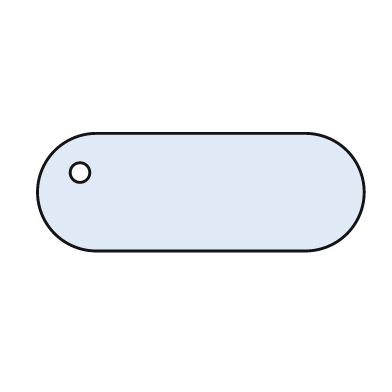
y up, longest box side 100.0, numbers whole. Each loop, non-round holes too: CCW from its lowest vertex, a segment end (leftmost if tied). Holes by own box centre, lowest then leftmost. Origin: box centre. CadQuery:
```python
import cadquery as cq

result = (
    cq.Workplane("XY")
    .moveTo(-32.0, -18.0)
    .lineTo(32.0, -18.0)
    .threePointArc((50.0, 0.0), (32.0, 18.0))
    .lineTo(-32.0, 18.0)
    .threePointArc((-50.0, 0.0), (-32.0, -18.0))
    .close()
    .moveTo(-37.0, 6.0)
    .circle(3.0)
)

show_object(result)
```